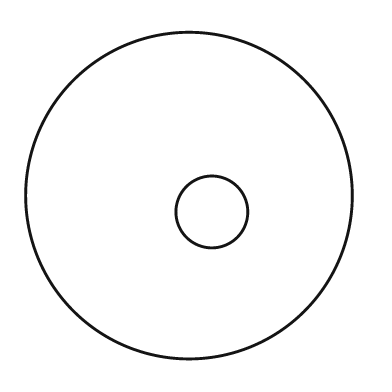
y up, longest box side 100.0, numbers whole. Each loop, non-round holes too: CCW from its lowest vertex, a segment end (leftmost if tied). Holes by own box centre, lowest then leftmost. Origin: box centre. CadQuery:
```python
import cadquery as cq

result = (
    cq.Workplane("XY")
    .moveTo(0.0, 0.0)
    .circle(50.0)
    .moveTo(7.0, -5.0)
    .circle(11.0)
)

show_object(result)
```